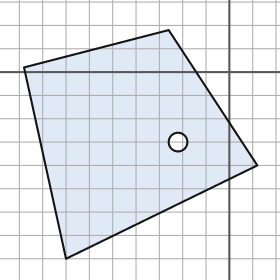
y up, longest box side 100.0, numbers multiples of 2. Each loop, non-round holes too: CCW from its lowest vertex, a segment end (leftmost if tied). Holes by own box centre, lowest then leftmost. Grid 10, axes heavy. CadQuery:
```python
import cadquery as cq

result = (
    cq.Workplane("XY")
    .moveTo(-70.0, -80.0)
    .lineTo(12.0, -40.0)
    .lineTo(-26.0, 18.0)
    .lineTo(-88.0, 2.0)
    .close()
    .moveTo(-22.0, -30.0)
    .circle(4.0)
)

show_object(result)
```